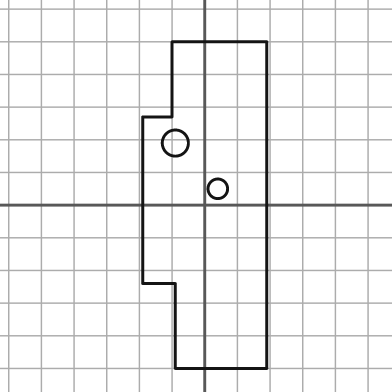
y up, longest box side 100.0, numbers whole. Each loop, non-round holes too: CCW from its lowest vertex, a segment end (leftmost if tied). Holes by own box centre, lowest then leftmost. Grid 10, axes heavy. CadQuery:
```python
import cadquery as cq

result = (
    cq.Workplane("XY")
    .moveTo(-9.0, -50.0)
    .lineTo(19.0, -50.0)
    .lineTo(19.0, 50.0)
    .lineTo(-10.0, 50.0)
    .lineTo(-10.0, 27.0)
    .lineTo(-19.0, 27.0)
    .lineTo(-19.0, -24.0)
    .lineTo(-9.0, -24.0)
    .close()
    .moveTo(4.0, 5.0)
    .circle(3.0)
    .moveTo(-9.0, 19.0)
    .circle(4.0)
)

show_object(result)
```